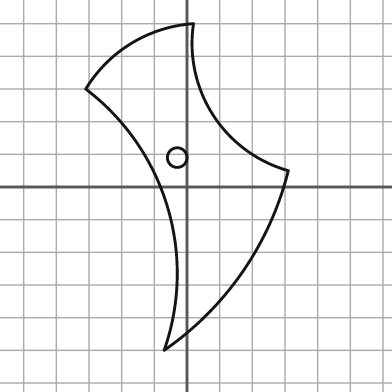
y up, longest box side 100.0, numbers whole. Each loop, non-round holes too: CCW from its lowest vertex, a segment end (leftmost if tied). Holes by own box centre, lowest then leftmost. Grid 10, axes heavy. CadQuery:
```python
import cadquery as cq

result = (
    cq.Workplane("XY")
    .moveTo(-7.0, -50.0)
    .threePointArc((17.0, -26.0), (31.0, 5.0))
    .threePointArc((8.0, 22.0), (2.0, 50.0))
    .threePointArc((-17.0, 44.0), (-31.0, 30.0))
    .threePointArc((-6.0, -6.0), (-7.0, -50.0))
    .close()
    .moveTo(-3.0, 9.0)
    .circle(3.0)
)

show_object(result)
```